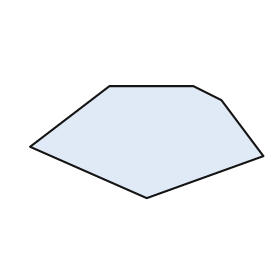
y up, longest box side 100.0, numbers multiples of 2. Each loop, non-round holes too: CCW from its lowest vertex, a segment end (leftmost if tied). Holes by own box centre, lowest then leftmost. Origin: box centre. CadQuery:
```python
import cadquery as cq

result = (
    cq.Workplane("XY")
    .moveTo(0.0, -24.0)
    .lineTo(50.0, -6.0)
    .lineTo(32.0, 18.0)
    .lineTo(20.0, 24.0)
    .lineTo(-16.0, 24.0)
    .lineTo(-50.0, -2.0)
    .close()
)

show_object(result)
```